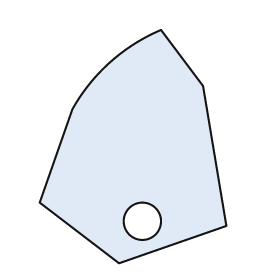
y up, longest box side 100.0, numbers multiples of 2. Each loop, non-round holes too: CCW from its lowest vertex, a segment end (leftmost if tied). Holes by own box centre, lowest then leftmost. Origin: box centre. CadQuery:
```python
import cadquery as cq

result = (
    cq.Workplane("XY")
    .moveTo(-6.0, -50.0)
    .lineTo(40.0, -34.0)
    .lineTo(30.0, 26.0)
    .lineTo(12.0, 50.0)
    .threePointArc((-10.0, 36.0), (-26.0, 16.0))
    .lineTo(-40.0, -24.0)
    .close()
    .moveTo(4.0, -32.0)
    .circle(8.0)
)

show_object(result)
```